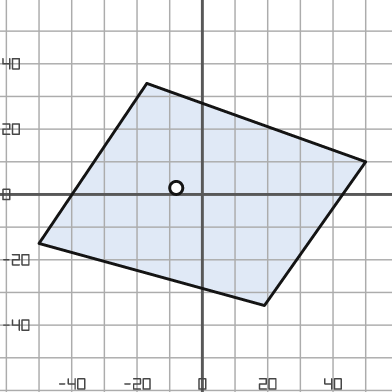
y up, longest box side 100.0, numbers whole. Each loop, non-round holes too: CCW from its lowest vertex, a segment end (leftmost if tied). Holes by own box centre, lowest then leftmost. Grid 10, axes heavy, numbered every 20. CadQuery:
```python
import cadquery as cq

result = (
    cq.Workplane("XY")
    .moveTo(19.0, -34.0)
    .lineTo(50.0, 10.0)
    .lineTo(-17.0, 34.0)
    .lineTo(-50.0, -15.0)
    .close()
    .moveTo(-8.0, 2.0)
    .circle(2.0)
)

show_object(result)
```